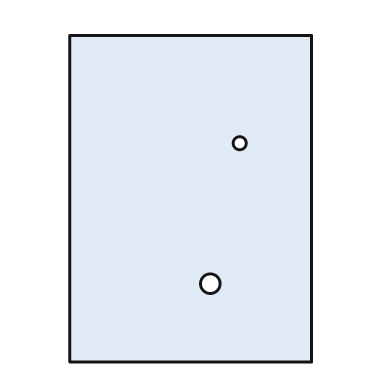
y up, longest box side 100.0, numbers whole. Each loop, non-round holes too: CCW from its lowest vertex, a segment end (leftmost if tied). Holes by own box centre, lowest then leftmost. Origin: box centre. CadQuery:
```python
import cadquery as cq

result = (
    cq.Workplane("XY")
    .moveTo(-37.0, -50.0)
    .lineTo(37.0, -50.0)
    .lineTo(37.0, 50.0)
    .lineTo(-37.0, 50.0)
    .close()
    .moveTo(6.0, -26.0)
    .circle(3.0)
    .moveTo(15.0, 17.0)
    .circle(2.0)
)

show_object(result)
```